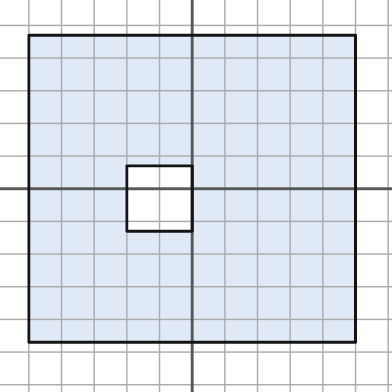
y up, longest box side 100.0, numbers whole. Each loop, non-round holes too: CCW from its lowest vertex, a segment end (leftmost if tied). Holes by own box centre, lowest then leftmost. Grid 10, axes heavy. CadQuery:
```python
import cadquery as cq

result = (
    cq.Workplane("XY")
    .moveTo(-50.0, -47.0)
    .lineTo(50.0, -47.0)
    .lineTo(50.0, 47.0)
    .lineTo(-50.0, 47.0)
    .close()
    .moveTo(-20.0, -13.0)
    .lineTo(0.0, -13.0)
    .lineTo(0.0, 7.0)
    .lineTo(-20.0, 7.0)
    .close()
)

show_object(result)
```